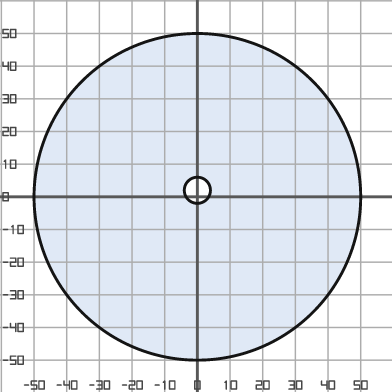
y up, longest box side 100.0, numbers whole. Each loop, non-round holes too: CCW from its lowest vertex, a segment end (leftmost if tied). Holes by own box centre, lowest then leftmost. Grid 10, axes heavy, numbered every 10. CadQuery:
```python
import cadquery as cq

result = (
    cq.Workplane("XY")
    .moveTo(0.0, 0.0)
    .circle(50.0)
    .moveTo(0.0, 2.0)
    .circle(4.0)
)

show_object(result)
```